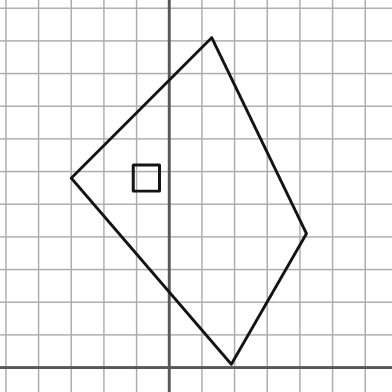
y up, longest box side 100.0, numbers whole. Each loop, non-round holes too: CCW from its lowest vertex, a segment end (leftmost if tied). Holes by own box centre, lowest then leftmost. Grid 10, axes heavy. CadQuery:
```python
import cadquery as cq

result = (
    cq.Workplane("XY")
    .moveTo(19.0, 1.0)
    .lineTo(42.0, 41.0)
    .lineTo(13.0, 101.0)
    .lineTo(-30.0, 58.0)
    .close()
    .moveTo(-11.0, 54.0)
    .lineTo(-3.0, 54.0)
    .lineTo(-3.0, 62.0)
    .lineTo(-11.0, 62.0)
    .close()
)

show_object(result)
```